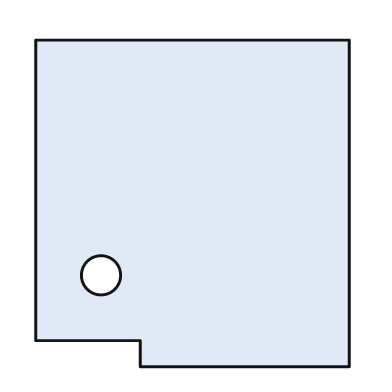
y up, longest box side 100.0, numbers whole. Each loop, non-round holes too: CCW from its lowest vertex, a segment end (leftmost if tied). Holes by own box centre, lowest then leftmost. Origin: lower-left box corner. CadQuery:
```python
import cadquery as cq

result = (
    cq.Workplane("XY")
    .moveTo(32.0, 0.0)
    .lineTo(96.0, 0.0)
    .lineTo(96.0, 100.0)
    .lineTo(0.0, 100.0)
    .lineTo(0.0, 8.0)
    .lineTo(32.0, 8.0)
    .close()
    .moveTo(20.0, 28.0)
    .circle(6.0)
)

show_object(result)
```